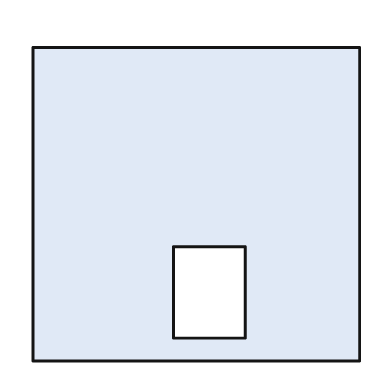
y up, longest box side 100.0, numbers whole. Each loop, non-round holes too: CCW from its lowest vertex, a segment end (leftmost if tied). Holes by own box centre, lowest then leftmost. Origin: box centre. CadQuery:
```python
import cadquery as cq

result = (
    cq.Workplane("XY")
    .moveTo(-50.0, -48.0)
    .lineTo(50.0, -48.0)
    .lineTo(50.0, 48.0)
    .lineTo(-50.0, 48.0)
    .close()
    .moveTo(-7.0, -41.0)
    .lineTo(15.0, -41.0)
    .lineTo(15.0, -13.0)
    .lineTo(-7.0, -13.0)
    .close()
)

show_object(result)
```